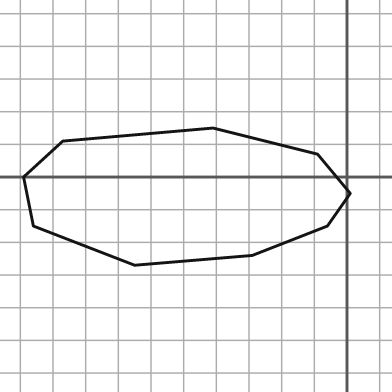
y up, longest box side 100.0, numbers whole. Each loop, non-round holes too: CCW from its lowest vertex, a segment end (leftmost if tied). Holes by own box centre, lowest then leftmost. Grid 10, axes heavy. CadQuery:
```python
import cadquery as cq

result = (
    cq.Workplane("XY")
    .moveTo(-65.0, -27.0)
    .lineTo(-29.0, -24.0)
    .lineTo(-6.0, -15.0)
    .lineTo(1.0, -5.0)
    .lineTo(-9.0, 7.0)
    .lineTo(-41.0, 15.0)
    .lineTo(-87.0, 11.0)
    .lineTo(-99.0, 0.0)
    .lineTo(-96.0, -15.0)
    .close()
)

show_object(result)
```